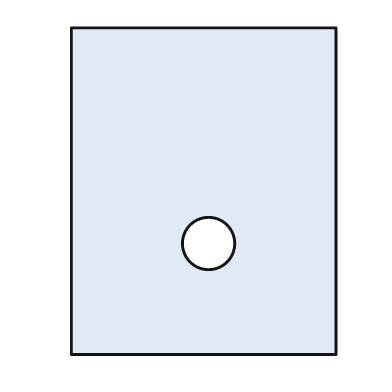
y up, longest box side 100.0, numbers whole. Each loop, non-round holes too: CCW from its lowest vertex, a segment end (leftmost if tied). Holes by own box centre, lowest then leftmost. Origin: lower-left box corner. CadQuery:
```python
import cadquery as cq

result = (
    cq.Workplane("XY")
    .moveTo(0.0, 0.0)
    .lineTo(81.0, 0.0)
    .lineTo(81.0, 100.0)
    .lineTo(0.0, 100.0)
    .close()
    .moveTo(42.0, 34.0)
    .circle(8.0)
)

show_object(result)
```